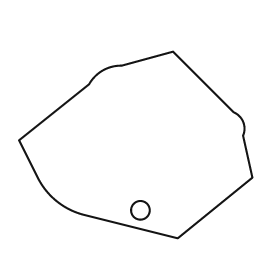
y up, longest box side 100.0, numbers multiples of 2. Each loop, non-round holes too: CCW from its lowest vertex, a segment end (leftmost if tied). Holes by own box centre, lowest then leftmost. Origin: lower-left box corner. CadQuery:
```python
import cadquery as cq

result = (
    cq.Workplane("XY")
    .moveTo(68.0, 0.0)
    .lineTo(100.0, 26.0)
    .lineTo(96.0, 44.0)
    .threePointArc((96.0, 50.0), (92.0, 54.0))
    .lineTo(66.0, 80.0)
    .lineTo(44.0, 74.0)
    .threePointArc((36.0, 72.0), (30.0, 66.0))
    .lineTo(0.0, 42.0)
    .lineTo(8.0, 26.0)
    .threePointArc((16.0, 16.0), (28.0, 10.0))
    .close()
    .moveTo(52.0, 12.0)
    .circle(4.0)
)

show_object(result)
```